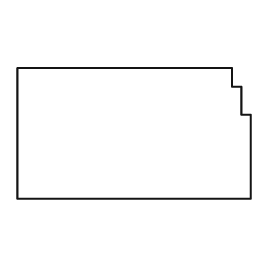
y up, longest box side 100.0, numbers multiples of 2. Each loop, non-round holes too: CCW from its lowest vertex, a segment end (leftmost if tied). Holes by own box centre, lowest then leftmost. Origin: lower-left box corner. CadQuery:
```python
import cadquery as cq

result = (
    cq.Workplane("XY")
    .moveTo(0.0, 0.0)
    .lineTo(100.0, 0.0)
    .lineTo(100.0, 36.0)
    .lineTo(96.0, 36.0)
    .lineTo(96.0, 48.0)
    .lineTo(92.0, 48.0)
    .lineTo(92.0, 56.0)
    .lineTo(0.0, 56.0)
    .close()
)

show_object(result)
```